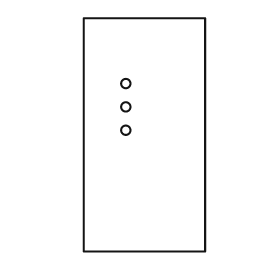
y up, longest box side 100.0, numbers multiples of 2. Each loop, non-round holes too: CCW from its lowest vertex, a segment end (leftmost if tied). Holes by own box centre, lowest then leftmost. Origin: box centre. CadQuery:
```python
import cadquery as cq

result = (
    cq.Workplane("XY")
    .moveTo(-26.0, -50.0)
    .lineTo(26.0, -50.0)
    .lineTo(26.0, 50.0)
    .lineTo(-26.0, 50.0)
    .close()
    .moveTo(-8.0, 2.0)
    .circle(2.0)
    .moveTo(-8.0, 12.0)
    .circle(2.0)
    .moveTo(-8.0, 22.0)
    .circle(2.0)
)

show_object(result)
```